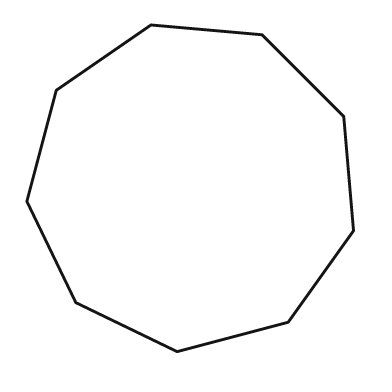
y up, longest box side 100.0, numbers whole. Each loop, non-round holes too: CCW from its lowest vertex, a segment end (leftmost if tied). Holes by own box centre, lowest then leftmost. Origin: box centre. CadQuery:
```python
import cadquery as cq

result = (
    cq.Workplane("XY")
    .moveTo(-4.0, -50.0)
    .lineTo(30.0, -41.0)
    .lineTo(50.0, -13.0)
    .lineTo(47.0, 22.0)
    .lineTo(22.0, 47.0)
    .lineTo(-12.0, 50.0)
    .lineTo(-41.0, 30.0)
    .lineTo(-50.0, -4.0)
    .lineTo(-35.0, -35.0)
    .close()
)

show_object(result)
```